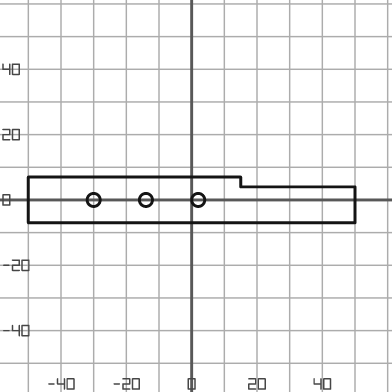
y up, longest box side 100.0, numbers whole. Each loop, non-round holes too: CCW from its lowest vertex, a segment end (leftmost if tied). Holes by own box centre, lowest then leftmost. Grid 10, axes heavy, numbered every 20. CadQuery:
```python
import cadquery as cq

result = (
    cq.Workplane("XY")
    .moveTo(-50.0, -7.0)
    .lineTo(50.0, -7.0)
    .lineTo(50.0, 4.0)
    .lineTo(15.0, 4.0)
    .lineTo(15.0, 7.0)
    .lineTo(-50.0, 7.0)
    .close()
    .moveTo(-30.0, 0.0)
    .circle(2.0)
    .moveTo(-14.0, 0.0)
    .circle(2.0)
    .moveTo(2.0, 0.0)
    .circle(2.0)
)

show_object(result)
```